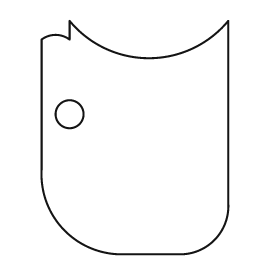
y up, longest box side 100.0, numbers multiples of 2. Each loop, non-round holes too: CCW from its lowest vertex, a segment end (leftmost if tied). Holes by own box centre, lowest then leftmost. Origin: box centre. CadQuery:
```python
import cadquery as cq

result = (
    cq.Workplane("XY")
    .moveTo(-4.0, -50.0)
    .lineTo(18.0, -50.0)
    .threePointArc((34.0, -44.0), (40.0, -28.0))
    .lineTo(40.0, 50.0)
    .threePointArc((6.0, 34.0), (-28.0, 50.0))
    .lineTo(-28.0, 42.0)
    .threePointArc((-34.0, 44.0), (-40.0, 42.0))
    .lineTo(-40.0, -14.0)
    .threePointArc((-30.0, -40.0), (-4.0, -50.0))
    .close()
    .moveTo(-28.0, 10.0)
    .circle(6.0)
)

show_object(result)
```